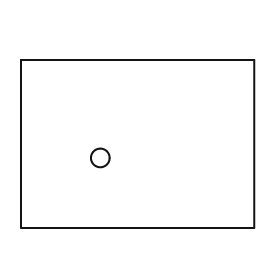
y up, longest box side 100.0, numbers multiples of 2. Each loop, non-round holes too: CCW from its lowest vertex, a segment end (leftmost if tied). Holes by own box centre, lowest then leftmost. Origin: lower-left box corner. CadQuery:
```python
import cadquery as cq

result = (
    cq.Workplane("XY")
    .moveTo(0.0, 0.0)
    .lineTo(100.0, 0.0)
    .lineTo(100.0, 72.0)
    .lineTo(0.0, 72.0)
    .close()
    .moveTo(34.0, 30.0)
    .circle(4.0)
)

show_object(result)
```